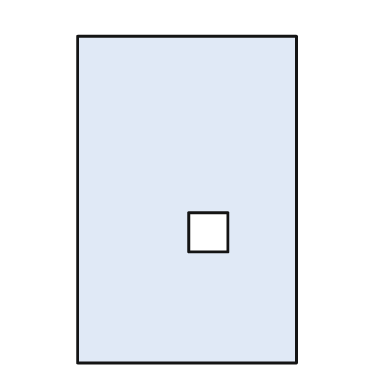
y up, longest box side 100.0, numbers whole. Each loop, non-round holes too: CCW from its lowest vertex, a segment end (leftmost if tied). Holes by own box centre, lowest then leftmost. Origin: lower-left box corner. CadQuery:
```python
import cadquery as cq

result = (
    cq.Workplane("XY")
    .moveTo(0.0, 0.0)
    .lineTo(67.0, 0.0)
    .lineTo(67.0, 100.0)
    .lineTo(0.0, 100.0)
    .close()
    .moveTo(34.0, 34.0)
    .lineTo(46.0, 34.0)
    .lineTo(46.0, 46.0)
    .lineTo(34.0, 46.0)
    .close()
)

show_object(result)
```